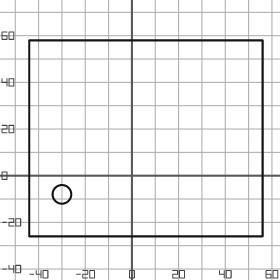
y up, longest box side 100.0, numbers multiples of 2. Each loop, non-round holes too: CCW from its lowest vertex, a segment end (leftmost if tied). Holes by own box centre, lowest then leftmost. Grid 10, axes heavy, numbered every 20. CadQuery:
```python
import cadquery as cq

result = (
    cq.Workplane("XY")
    .moveTo(-44.0, -26.0)
    .lineTo(56.0, -26.0)
    .lineTo(56.0, 58.0)
    .lineTo(-44.0, 58.0)
    .close()
    .moveTo(-30.0, -8.0)
    .circle(4.0)
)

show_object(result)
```